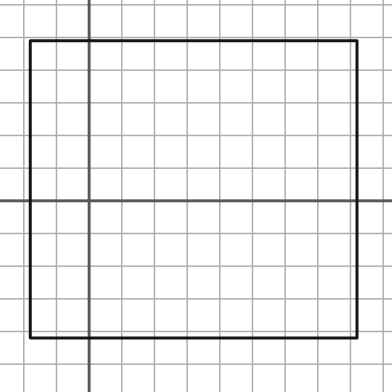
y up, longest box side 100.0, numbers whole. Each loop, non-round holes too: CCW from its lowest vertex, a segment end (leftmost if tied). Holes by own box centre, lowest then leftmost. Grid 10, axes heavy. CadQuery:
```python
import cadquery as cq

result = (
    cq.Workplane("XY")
    .moveTo(-18.0, -42.0)
    .lineTo(82.0, -42.0)
    .lineTo(82.0, 49.0)
    .lineTo(-18.0, 49.0)
    .close()
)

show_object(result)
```